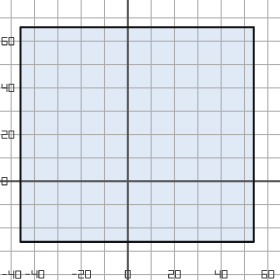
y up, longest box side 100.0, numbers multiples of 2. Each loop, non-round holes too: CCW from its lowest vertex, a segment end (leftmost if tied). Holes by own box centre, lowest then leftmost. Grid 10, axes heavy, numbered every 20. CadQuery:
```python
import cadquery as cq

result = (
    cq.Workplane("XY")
    .moveTo(-46.0, -26.0)
    .lineTo(54.0, -26.0)
    .lineTo(54.0, 66.0)
    .lineTo(-46.0, 66.0)
    .close()
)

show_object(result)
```